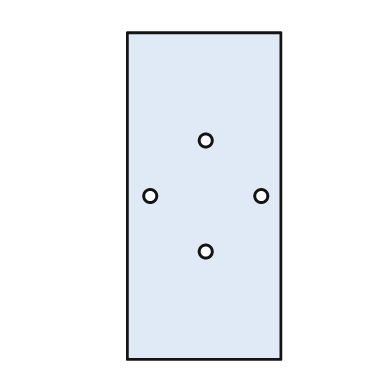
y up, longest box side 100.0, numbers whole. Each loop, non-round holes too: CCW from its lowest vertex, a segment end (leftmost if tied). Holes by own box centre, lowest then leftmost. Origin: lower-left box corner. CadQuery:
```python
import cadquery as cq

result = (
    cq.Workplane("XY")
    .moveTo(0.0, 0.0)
    .lineTo(47.0, 0.0)
    .lineTo(47.0, 100.0)
    .lineTo(0.0, 100.0)
    .close()
    .moveTo(24.0, 33.0)
    .circle(2.0)
    .moveTo(7.0, 50.0)
    .circle(2.0)
    .moveTo(41.0, 50.0)
    .circle(2.0)
    .moveTo(24.0, 67.0)
    .circle(2.0)
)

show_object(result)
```